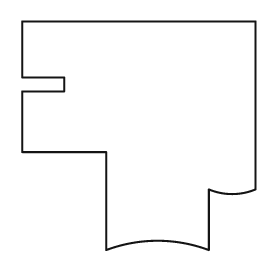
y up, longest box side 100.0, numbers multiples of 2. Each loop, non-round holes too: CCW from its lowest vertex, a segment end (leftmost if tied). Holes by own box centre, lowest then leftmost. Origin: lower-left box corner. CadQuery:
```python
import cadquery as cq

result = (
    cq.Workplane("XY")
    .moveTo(36.0, 0.0)
    .threePointArc((58.0, 4.0), (80.0, 0.0))
    .lineTo(80.0, 26.0)
    .threePointArc((90.0, 24.0), (100.0, 26.0))
    .lineTo(100.0, 98.0)
    .lineTo(0.0, 98.0)
    .lineTo(0.0, 74.0)
    .lineTo(18.0, 74.0)
    .lineTo(18.0, 68.0)
    .lineTo(0.0, 68.0)
    .lineTo(0.0, 42.0)
    .lineTo(36.0, 42.0)
    .close()
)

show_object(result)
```